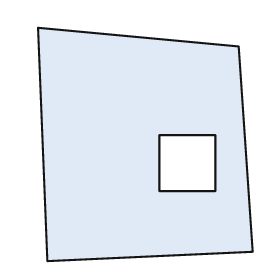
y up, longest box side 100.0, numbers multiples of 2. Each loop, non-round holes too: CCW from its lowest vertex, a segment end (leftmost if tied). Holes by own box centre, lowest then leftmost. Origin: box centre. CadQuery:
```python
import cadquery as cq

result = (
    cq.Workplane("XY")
    .moveTo(-42.0, -50.0)
    .lineTo(46.0, -46.0)
    .lineTo(40.0, 42.0)
    .lineTo(-46.0, 50.0)
    .close()
    .moveTo(6.0, -20.0)
    .lineTo(30.0, -20.0)
    .lineTo(30.0, 4.0)
    .lineTo(6.0, 4.0)
    .close()
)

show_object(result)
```